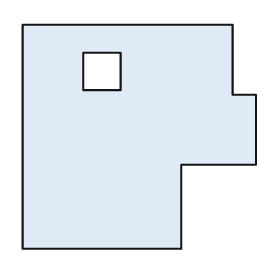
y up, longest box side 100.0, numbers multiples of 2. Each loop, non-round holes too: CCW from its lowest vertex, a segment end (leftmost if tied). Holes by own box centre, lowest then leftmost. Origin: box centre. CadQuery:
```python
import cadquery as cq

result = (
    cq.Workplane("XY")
    .moveTo(-50.0, -48.0)
    .lineTo(18.0, -48.0)
    .lineTo(18.0, -12.0)
    .lineTo(50.0, -12.0)
    .lineTo(50.0, 18.0)
    .lineTo(40.0, 18.0)
    .lineTo(40.0, 48.0)
    .lineTo(-50.0, 48.0)
    .close()
    .moveTo(-24.0, 20.0)
    .lineTo(-8.0, 20.0)
    .lineTo(-8.0, 36.0)
    .lineTo(-24.0, 36.0)
    .close()
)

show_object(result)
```